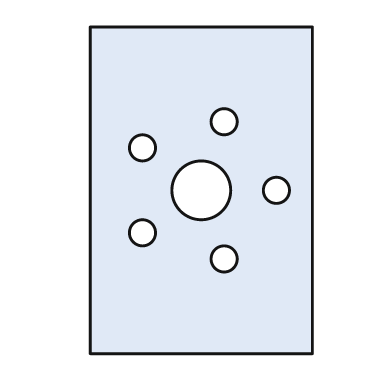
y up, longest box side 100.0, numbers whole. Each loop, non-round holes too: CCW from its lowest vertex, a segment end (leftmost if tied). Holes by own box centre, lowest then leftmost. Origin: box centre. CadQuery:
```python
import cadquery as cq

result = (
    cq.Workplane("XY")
    .moveTo(-34.0, -50.0)
    .lineTo(34.0, -50.0)
    .lineTo(34.0, 50.0)
    .lineTo(-34.0, 50.0)
    .close()
    .moveTo(7.0, -21.0)
    .circle(4.0)
    .moveTo(-18.0, -13.0)
    .circle(4.0)
    .moveTo(0.0, 0.0)
    .circle(9.0)
    .moveTo(23.0, 0.0)
    .circle(4.0)
    .moveTo(-18.0, 13.0)
    .circle(4.0)
    .moveTo(7.0, 21.0)
    .circle(4.0)
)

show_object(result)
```